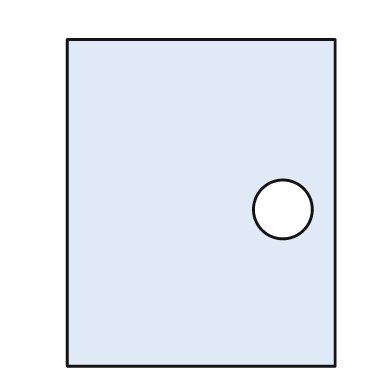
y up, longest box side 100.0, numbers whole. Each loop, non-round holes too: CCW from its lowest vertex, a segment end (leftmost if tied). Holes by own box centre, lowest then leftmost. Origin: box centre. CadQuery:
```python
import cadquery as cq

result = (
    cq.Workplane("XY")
    .moveTo(-41.0, -50.0)
    .lineTo(41.0, -50.0)
    .lineTo(41.0, 50.0)
    .lineTo(-41.0, 50.0)
    .close()
    .moveTo(25.0, -2.0)
    .circle(9.0)
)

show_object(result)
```